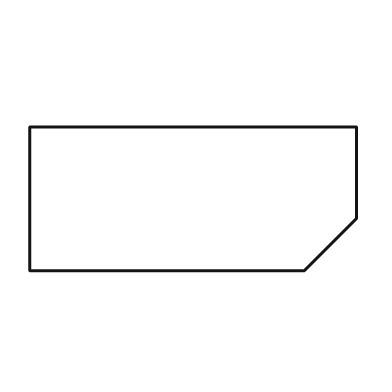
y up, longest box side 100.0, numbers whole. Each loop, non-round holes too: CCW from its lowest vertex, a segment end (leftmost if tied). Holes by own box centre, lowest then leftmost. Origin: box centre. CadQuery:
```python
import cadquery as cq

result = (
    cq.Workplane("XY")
    .moveTo(-50.0, -22.0)
    .lineTo(34.0, -22.0)
    .lineTo(50.0, -6.0)
    .lineTo(50.0, 22.0)
    .lineTo(-50.0, 22.0)
    .close()
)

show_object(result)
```